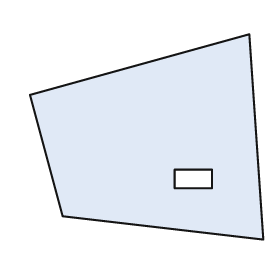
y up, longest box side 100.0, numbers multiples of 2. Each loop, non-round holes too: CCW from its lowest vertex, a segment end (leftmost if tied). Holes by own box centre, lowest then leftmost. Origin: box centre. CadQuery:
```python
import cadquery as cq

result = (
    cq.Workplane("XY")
    .moveTo(50.0, -44.0)
    .lineTo(44.0, 44.0)
    .lineTo(-50.0, 18.0)
    .lineTo(-36.0, -34.0)
    .close()
    .moveTo(12.0, -22.0)
    .lineTo(28.0, -22.0)
    .lineTo(28.0, -14.0)
    .lineTo(12.0, -14.0)
    .close()
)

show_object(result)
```